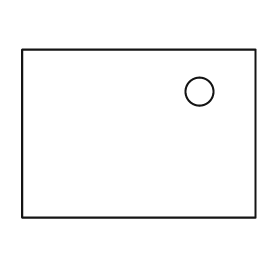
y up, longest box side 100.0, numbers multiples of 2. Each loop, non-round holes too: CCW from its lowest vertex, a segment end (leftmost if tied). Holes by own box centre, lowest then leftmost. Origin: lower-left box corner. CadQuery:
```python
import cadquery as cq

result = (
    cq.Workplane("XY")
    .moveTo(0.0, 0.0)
    .lineTo(100.0, 0.0)
    .lineTo(100.0, 72.0)
    .lineTo(0.0, 72.0)
    .close()
    .moveTo(76.0, 54.0)
    .circle(6.0)
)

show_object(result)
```